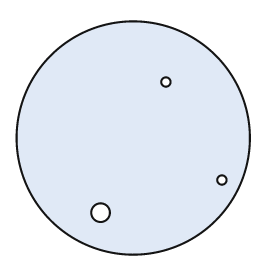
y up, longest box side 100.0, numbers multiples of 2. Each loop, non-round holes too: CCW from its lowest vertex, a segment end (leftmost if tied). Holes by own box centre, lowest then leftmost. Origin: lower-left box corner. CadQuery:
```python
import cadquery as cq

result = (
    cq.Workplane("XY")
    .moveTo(50.0, 50.0)
    .circle(50.0)
    .moveTo(36.0, 18.0)
    .circle(4.0)
    .moveTo(88.0, 32.0)
    .circle(2.0)
    .moveTo(64.0, 74.0)
    .circle(2.0)
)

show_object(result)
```